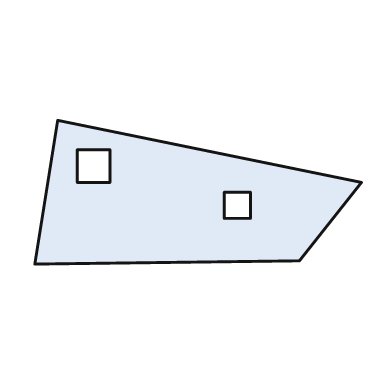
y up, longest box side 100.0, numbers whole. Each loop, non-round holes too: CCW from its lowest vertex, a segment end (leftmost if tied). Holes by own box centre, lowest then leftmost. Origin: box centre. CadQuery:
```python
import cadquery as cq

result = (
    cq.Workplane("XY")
    .moveTo(-50.0, -22.0)
    .lineTo(31.0, -21.0)
    .lineTo(50.0, 3.0)
    .lineTo(-43.0, 22.0)
    .close()
    .moveTo(8.0, -8.0)
    .lineTo(16.0, -8.0)
    .lineTo(16.0, 0.0)
    .lineTo(8.0, 0.0)
    .close()
    .moveTo(-37.0, 3.0)
    .lineTo(-27.0, 3.0)
    .lineTo(-27.0, 13.0)
    .lineTo(-37.0, 13.0)
    .close()
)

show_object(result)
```